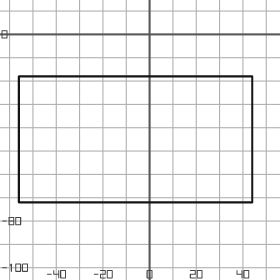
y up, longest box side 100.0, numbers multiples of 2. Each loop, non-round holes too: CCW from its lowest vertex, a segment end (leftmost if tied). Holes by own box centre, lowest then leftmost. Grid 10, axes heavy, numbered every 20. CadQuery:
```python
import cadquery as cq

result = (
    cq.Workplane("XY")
    .moveTo(-56.0, -72.0)
    .lineTo(44.0, -72.0)
    .lineTo(44.0, -18.0)
    .lineTo(-56.0, -18.0)
    .close()
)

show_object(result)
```